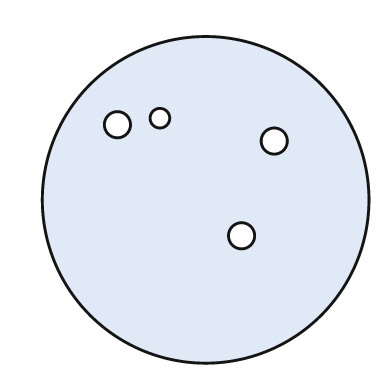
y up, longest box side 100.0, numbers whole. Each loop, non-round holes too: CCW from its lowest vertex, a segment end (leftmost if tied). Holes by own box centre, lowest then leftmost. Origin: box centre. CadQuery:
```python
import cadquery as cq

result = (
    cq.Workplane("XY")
    .moveTo(0.0, 0.0)
    .circle(50.0)
    .moveTo(11.0, -11.0)
    .circle(4.0)
    .moveTo(21.0, 18.0)
    .circle(4.0)
    .moveTo(-27.0, 23.0)
    .circle(4.0)
    .moveTo(-14.0, 25.0)
    .circle(3.0)
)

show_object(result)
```